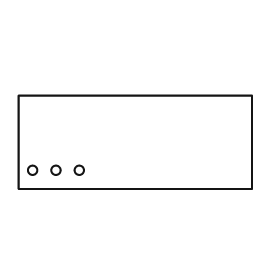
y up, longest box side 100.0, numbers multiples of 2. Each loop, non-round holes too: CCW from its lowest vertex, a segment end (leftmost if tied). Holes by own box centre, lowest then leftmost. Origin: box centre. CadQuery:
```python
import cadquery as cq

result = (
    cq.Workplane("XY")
    .moveTo(-50.0, -20.0)
    .lineTo(50.0, -20.0)
    .lineTo(50.0, 20.0)
    .lineTo(-50.0, 20.0)
    .close()
    .moveTo(-44.0, -12.0)
    .circle(2.0)
    .moveTo(-34.0, -12.0)
    .circle(2.0)
    .moveTo(-24.0, -12.0)
    .circle(2.0)
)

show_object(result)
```